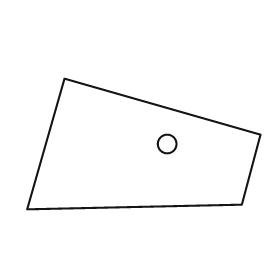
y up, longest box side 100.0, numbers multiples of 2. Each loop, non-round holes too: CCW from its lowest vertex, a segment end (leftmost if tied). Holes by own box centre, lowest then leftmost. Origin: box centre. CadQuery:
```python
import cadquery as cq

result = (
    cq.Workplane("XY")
    .moveTo(-50.0, -28.0)
    .lineTo(42.0, -26.0)
    .lineTo(50.0, 4.0)
    .lineTo(-34.0, 28.0)
    .close()
    .moveTo(10.0, 0.0)
    .circle(4.0)
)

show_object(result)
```